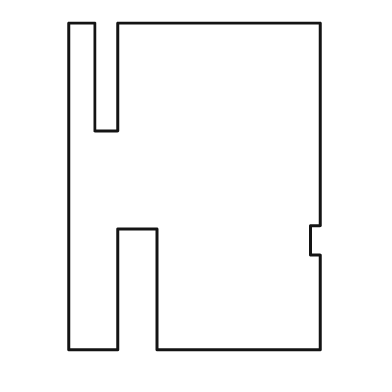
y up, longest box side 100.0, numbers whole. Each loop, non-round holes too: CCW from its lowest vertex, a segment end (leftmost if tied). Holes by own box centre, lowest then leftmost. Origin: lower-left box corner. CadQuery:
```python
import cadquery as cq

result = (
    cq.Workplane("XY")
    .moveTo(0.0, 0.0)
    .lineTo(15.0, 0.0)
    .lineTo(15.0, 37.0)
    .lineTo(27.0, 37.0)
    .lineTo(27.0, 0.0)
    .lineTo(77.0, 0.0)
    .lineTo(77.0, 29.0)
    .lineTo(74.0, 29.0)
    .lineTo(74.0, 38.0)
    .lineTo(77.0, 38.0)
    .lineTo(77.0, 100.0)
    .lineTo(15.0, 100.0)
    .lineTo(15.0, 67.0)
    .lineTo(8.0, 67.0)
    .lineTo(8.0, 100.0)
    .lineTo(0.0, 100.0)
    .close()
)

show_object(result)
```